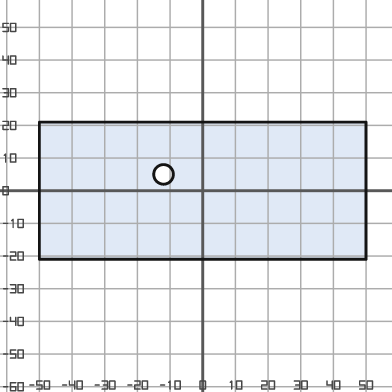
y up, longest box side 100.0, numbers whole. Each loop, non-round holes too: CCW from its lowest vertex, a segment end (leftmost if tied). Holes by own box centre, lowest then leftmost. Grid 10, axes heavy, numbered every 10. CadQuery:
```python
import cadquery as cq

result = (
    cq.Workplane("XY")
    .moveTo(-50.0, -21.0)
    .lineTo(50.0, -21.0)
    .lineTo(50.0, 21.0)
    .lineTo(-50.0, 21.0)
    .close()
    .moveTo(-12.0, 5.0)
    .circle(3.0)
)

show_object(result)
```